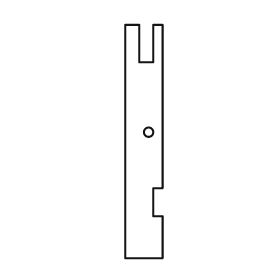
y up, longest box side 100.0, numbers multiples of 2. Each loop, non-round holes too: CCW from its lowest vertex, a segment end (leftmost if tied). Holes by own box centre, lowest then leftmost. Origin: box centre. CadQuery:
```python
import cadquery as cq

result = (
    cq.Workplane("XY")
    .moveTo(-8.0, -50.0)
    .lineTo(8.0, -50.0)
    .lineTo(8.0, -32.0)
    .lineTo(4.0, -32.0)
    .lineTo(4.0, -20.0)
    .lineTo(8.0, -20.0)
    .lineTo(8.0, 50.0)
    .lineTo(4.0, 50.0)
    .lineTo(4.0, 34.0)
    .lineTo(-2.0, 34.0)
    .lineTo(-2.0, 50.0)
    .lineTo(-8.0, 50.0)
    .close()
    .moveTo(2.0, 4.0)
    .circle(2.0)
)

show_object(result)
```